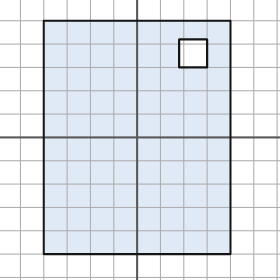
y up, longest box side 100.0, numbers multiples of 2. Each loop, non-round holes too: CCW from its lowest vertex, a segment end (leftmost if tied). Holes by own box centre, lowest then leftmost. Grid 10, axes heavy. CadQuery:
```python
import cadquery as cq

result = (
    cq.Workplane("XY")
    .moveTo(-40.0, -50.0)
    .lineTo(40.0, -50.0)
    .lineTo(40.0, 50.0)
    .lineTo(-40.0, 50.0)
    .close()
    .moveTo(18.0, 30.0)
    .lineTo(30.0, 30.0)
    .lineTo(30.0, 42.0)
    .lineTo(18.0, 42.0)
    .close()
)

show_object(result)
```